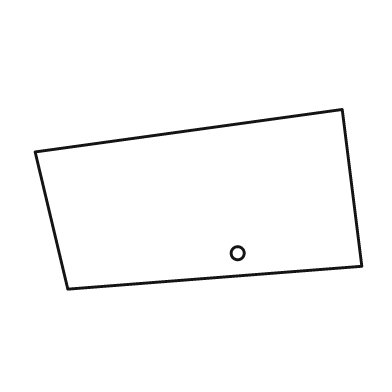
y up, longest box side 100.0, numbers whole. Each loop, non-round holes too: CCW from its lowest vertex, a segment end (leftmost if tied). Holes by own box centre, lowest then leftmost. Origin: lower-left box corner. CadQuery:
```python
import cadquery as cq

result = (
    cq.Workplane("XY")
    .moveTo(10.0, 0.0)
    .lineTo(100.0, 7.0)
    .lineTo(94.0, 55.0)
    .lineTo(0.0, 42.0)
    .close()
    .moveTo(62.0, 11.0)
    .circle(2.0)
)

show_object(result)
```